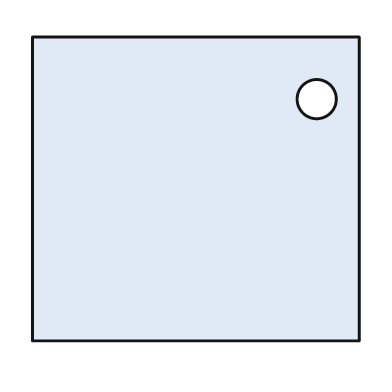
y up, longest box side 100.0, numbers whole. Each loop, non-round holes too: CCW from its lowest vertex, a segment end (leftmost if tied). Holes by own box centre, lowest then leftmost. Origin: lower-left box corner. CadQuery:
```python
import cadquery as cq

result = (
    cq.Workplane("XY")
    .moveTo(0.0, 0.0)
    .lineTo(100.0, 0.0)
    .lineTo(100.0, 93.0)
    .lineTo(0.0, 93.0)
    .close()
    .moveTo(87.0, 74.0)
    .circle(6.0)
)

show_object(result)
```